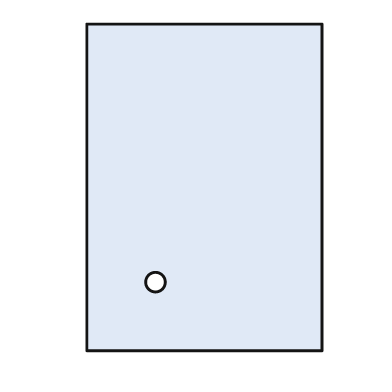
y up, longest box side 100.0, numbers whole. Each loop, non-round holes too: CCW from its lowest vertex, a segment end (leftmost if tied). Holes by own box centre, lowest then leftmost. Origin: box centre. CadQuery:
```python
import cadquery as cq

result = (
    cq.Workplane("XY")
    .moveTo(-36.0, -50.0)
    .lineTo(36.0, -50.0)
    .lineTo(36.0, 50.0)
    .lineTo(-36.0, 50.0)
    .close()
    .moveTo(-15.0, -29.0)
    .circle(3.0)
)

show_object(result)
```